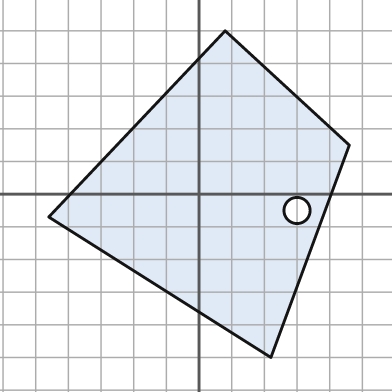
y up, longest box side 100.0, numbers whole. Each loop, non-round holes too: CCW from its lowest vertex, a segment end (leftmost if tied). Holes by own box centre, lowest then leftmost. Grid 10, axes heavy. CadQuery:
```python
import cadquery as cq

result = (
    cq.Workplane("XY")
    .moveTo(22.0, -50.0)
    .lineTo(46.0, 15.0)
    .lineTo(8.0, 50.0)
    .lineTo(-46.0, -7.0)
    .close()
    .moveTo(30.0, -5.0)
    .circle(4.0)
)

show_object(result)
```